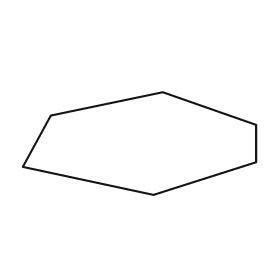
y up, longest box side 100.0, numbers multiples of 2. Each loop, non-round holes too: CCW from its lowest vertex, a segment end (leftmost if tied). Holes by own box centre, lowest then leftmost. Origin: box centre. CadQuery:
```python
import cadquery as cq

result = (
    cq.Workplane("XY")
    .moveTo(6.0, -22.0)
    .lineTo(50.0, -8.0)
    .lineTo(50.0, 8.0)
    .lineTo(10.0, 22.0)
    .lineTo(-38.0, 12.0)
    .lineTo(-50.0, -10.0)
    .close()
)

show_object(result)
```